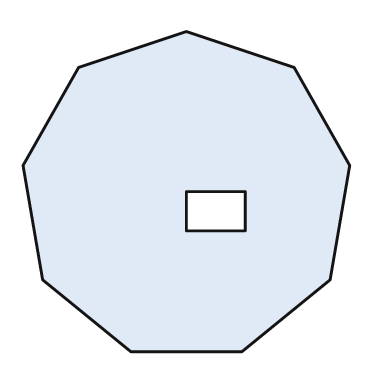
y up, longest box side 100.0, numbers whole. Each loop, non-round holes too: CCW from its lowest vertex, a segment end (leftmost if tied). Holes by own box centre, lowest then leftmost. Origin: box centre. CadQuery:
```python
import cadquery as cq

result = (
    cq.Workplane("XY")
    .moveTo(-17.0, -49.0)
    .lineTo(17.0, -49.0)
    .lineTo(44.0, -27.0)
    .lineTo(50.0, 8.0)
    .lineTo(33.0, 38.0)
    .lineTo(0.0, 49.0)
    .lineTo(-33.0, 38.0)
    .lineTo(-50.0, 8.0)
    .lineTo(-44.0, -27.0)
    .close()
    .moveTo(0.0, -12.0)
    .lineTo(18.0, -12.0)
    .lineTo(18.0, 0.0)
    .lineTo(0.0, 0.0)
    .close()
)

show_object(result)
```